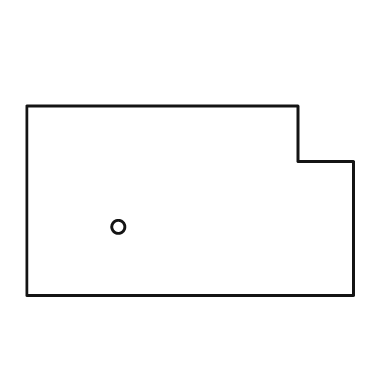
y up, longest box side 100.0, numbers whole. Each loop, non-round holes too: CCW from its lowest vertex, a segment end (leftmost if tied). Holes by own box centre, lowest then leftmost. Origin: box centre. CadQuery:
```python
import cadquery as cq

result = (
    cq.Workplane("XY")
    .moveTo(-50.0, -29.0)
    .lineTo(50.0, -29.0)
    .lineTo(50.0, 12.0)
    .lineTo(33.0, 12.0)
    .lineTo(33.0, 29.0)
    .lineTo(-50.0, 29.0)
    .close()
    .moveTo(-22.0, -8.0)
    .circle(2.0)
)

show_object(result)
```